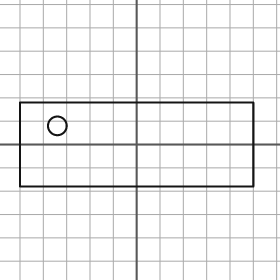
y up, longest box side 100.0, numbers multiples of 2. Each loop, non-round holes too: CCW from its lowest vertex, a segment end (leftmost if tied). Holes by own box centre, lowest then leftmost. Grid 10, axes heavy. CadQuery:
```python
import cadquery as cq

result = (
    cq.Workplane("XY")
    .moveTo(-50.0, -18.0)
    .lineTo(50.0, -18.0)
    .lineTo(50.0, 18.0)
    .lineTo(-50.0, 18.0)
    .close()
    .moveTo(-34.0, 8.0)
    .circle(4.0)
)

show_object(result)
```